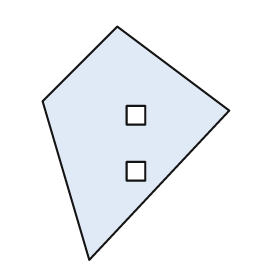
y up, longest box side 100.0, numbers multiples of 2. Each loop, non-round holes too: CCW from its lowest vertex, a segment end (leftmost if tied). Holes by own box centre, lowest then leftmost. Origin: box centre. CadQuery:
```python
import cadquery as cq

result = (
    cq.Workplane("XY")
    .moveTo(-20.0, -50.0)
    .lineTo(40.0, 14.0)
    .lineTo(-8.0, 50.0)
    .lineTo(-40.0, 18.0)
    .close()
    .moveTo(-4.0, -16.0)
    .lineTo(4.0, -16.0)
    .lineTo(4.0, -8.0)
    .lineTo(-4.0, -8.0)
    .close()
    .moveTo(-4.0, 8.0)
    .lineTo(4.0, 8.0)
    .lineTo(4.0, 16.0)
    .lineTo(-4.0, 16.0)
    .close()
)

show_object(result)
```